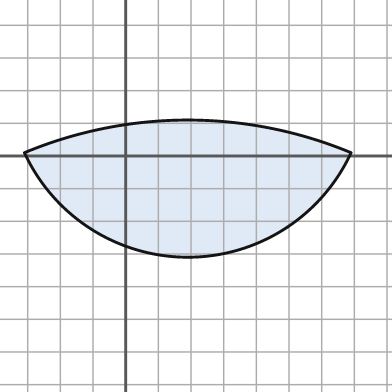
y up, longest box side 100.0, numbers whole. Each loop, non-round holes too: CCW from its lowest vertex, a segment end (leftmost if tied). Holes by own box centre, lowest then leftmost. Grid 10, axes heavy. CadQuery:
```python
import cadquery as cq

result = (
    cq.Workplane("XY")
    .moveTo(-31.0, 1.0)
    .threePointArc((19.0, -31.0), (69.0, 1.0))
    .threePointArc((19.0, 11.0), (-31.0, 1.0))
    .close()
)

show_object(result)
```